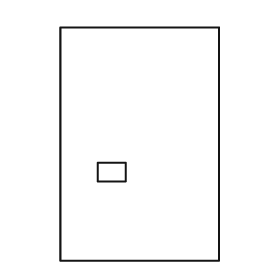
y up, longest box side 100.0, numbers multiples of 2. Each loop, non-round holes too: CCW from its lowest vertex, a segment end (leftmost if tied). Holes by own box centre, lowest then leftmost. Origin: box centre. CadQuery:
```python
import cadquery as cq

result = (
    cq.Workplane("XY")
    .moveTo(-34.0, -50.0)
    .lineTo(34.0, -50.0)
    .lineTo(34.0, 50.0)
    .lineTo(-34.0, 50.0)
    .close()
    .moveTo(-18.0, -16.0)
    .lineTo(-6.0, -16.0)
    .lineTo(-6.0, -8.0)
    .lineTo(-18.0, -8.0)
    .close()
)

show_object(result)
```